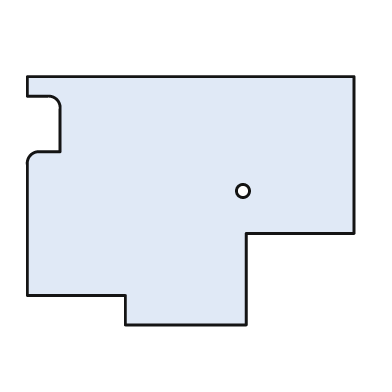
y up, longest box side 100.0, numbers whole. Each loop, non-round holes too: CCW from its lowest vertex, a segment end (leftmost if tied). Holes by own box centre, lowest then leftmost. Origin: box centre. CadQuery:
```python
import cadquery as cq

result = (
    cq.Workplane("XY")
    .moveTo(-20.0, -38.0)
    .lineTo(17.0, -38.0)
    .lineTo(17.0, -10.0)
    .lineTo(50.0, -10.0)
    .lineTo(50.0, 38.0)
    .lineTo(-50.0, 38.0)
    .lineTo(-50.0, 32.0)
    .lineTo(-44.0, 32.0)
    .threePointArc((-41.0, 31.0), (-40.0, 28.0))
    .lineTo(-40.0, 15.0)
    .lineTo(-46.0, 15.0)
    .threePointArc((-49.0, 14.0), (-50.0, 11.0))
    .lineTo(-50.0, -29.0)
    .lineTo(-20.0, -29.0)
    .close()
    .moveTo(16.0, 3.0)
    .circle(2.0)
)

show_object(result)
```